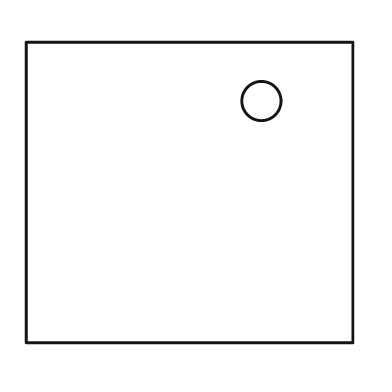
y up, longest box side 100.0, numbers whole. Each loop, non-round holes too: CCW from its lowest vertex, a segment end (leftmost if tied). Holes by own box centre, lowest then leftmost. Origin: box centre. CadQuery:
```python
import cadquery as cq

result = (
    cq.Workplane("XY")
    .moveTo(-50.0, -46.0)
    .lineTo(50.0, -46.0)
    .lineTo(50.0, 46.0)
    .lineTo(-50.0, 46.0)
    .close()
    .moveTo(22.0, 28.0)
    .circle(6.0)
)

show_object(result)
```